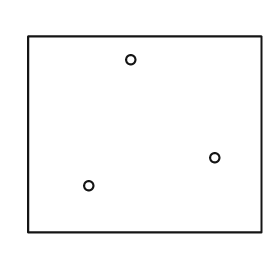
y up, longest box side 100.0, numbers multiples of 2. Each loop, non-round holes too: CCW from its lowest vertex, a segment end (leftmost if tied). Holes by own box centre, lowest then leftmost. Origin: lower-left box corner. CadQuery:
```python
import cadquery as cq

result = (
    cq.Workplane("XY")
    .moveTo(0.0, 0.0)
    .lineTo(100.0, 0.0)
    .lineTo(100.0, 84.0)
    .lineTo(0.0, 84.0)
    .close()
    .moveTo(26.0, 20.0)
    .circle(2.0)
    .moveTo(80.0, 32.0)
    .circle(2.0)
    .moveTo(44.0, 74.0)
    .circle(2.0)
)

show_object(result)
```